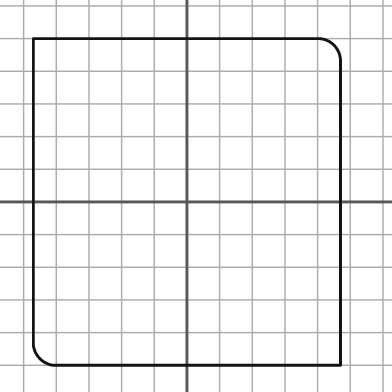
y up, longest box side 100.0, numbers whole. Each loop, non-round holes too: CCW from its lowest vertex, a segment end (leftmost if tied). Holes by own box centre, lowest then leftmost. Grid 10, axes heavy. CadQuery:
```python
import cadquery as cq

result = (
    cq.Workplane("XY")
    .moveTo(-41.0, -50.0)
    .lineTo(47.0, -50.0)
    .lineTo(47.0, 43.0)
    .threePointArc((45.0, 48.0), (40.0, 50.0))
    .lineTo(-47.0, 50.0)
    .lineTo(-47.0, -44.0)
    .threePointArc((-45.0, -48.0), (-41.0, -50.0))
    .close()
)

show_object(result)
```